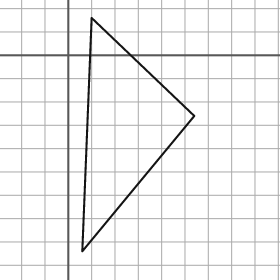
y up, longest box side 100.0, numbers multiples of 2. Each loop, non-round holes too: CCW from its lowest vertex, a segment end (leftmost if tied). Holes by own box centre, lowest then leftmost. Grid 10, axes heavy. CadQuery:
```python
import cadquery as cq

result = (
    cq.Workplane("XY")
    .moveTo(6.0, -84.0)
    .lineTo(54.0, -26.0)
    .lineTo(10.0, 16.0)
    .close()
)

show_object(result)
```